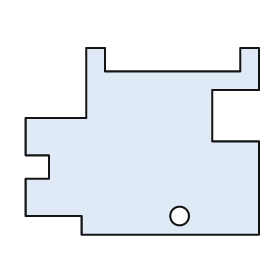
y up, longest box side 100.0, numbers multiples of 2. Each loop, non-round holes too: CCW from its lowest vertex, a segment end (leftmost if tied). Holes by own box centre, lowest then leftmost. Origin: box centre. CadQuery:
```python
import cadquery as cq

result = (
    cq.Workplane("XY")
    .moveTo(-26.0, -40.0)
    .lineTo(50.0, -40.0)
    .lineTo(50.0, 0.0)
    .lineTo(30.0, 0.0)
    .lineTo(30.0, 22.0)
    .lineTo(50.0, 22.0)
    .lineTo(50.0, 40.0)
    .lineTo(42.0, 40.0)
    .lineTo(42.0, 30.0)
    .lineTo(-16.0, 30.0)
    .lineTo(-16.0, 40.0)
    .lineTo(-24.0, 40.0)
    .lineTo(-24.0, 10.0)
    .lineTo(-50.0, 10.0)
    .lineTo(-50.0, -6.0)
    .lineTo(-40.0, -6.0)
    .lineTo(-40.0, -16.0)
    .lineTo(-50.0, -16.0)
    .lineTo(-50.0, -32.0)
    .lineTo(-26.0, -32.0)
    .close()
    .moveTo(16.0, -32.0)
    .circle(4.0)
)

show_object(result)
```